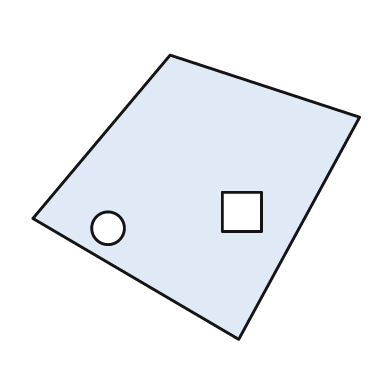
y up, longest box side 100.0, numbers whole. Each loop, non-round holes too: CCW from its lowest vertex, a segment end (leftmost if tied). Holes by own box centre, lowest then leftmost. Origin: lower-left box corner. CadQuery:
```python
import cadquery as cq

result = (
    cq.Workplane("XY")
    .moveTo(63.0, 0.0)
    .lineTo(100.0, 68.0)
    .lineTo(42.0, 87.0)
    .lineTo(0.0, 37.0)
    .close()
    .moveTo(23.0, 34.0)
    .circle(5.0)
    .moveTo(58.0, 33.0)
    .lineTo(70.0, 33.0)
    .lineTo(70.0, 45.0)
    .lineTo(58.0, 45.0)
    .close()
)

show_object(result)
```